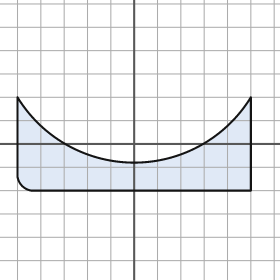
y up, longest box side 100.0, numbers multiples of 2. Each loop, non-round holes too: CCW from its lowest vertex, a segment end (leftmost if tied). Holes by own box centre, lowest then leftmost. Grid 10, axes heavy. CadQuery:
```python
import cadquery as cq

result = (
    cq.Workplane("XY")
    .moveTo(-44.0, -20.0)
    .lineTo(50.0, -20.0)
    .lineTo(50.0, 20.0)
    .threePointArc((0.0, -8.0), (-50.0, 20.0))
    .lineTo(-50.0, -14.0)
    .threePointArc((-48.0, -18.0), (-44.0, -20.0))
    .close()
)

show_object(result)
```